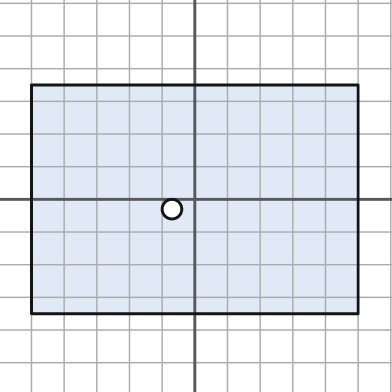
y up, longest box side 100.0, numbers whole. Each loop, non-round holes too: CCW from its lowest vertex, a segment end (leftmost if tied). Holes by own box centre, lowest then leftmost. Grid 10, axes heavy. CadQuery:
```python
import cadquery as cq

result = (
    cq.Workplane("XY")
    .moveTo(-50.0, -35.0)
    .lineTo(50.0, -35.0)
    .lineTo(50.0, 35.0)
    .lineTo(-50.0, 35.0)
    .close()
    .moveTo(-7.0, -3.0)
    .circle(3.0)
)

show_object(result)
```